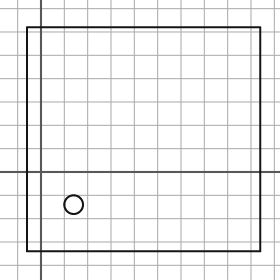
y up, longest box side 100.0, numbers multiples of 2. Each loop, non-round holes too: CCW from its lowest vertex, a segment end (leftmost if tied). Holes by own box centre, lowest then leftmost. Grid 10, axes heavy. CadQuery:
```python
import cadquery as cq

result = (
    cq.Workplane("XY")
    .moveTo(-6.0, -34.0)
    .lineTo(94.0, -34.0)
    .lineTo(94.0, 62.0)
    .lineTo(-6.0, 62.0)
    .close()
    .moveTo(14.0, -14.0)
    .circle(4.0)
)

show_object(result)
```